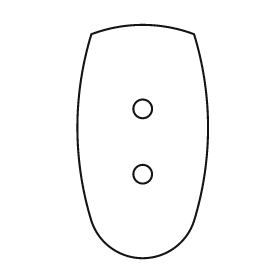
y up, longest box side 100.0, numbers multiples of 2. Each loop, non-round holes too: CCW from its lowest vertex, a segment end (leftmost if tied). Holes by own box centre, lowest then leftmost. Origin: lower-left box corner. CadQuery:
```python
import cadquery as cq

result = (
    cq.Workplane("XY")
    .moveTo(6.0, 16.0)
    .threePointArc((28.0, 0.0), (50.0, 16.0))
    .threePointArc((56.0, 56.0), (50.0, 96.0))
    .threePointArc((28.0, 100.0), (6.0, 96.0))
    .threePointArc((0.0, 56.0), (6.0, 16.0))
    .close()
    .moveTo(28.0, 36.0)
    .circle(4.0)
    .moveTo(28.0, 64.0)
    .circle(4.0)
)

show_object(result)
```